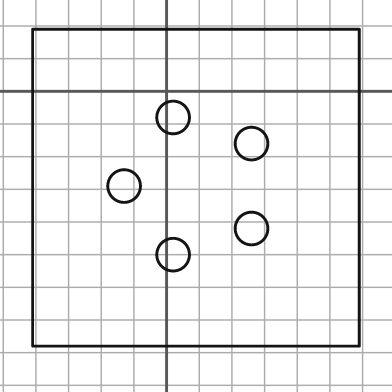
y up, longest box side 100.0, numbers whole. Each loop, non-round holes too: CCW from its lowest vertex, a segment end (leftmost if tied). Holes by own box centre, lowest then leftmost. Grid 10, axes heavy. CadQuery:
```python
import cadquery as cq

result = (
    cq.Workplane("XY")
    .moveTo(-41.0, -78.0)
    .lineTo(59.0, -78.0)
    .lineTo(59.0, 19.0)
    .lineTo(-41.0, 19.0)
    .close()
    .moveTo(2.0, -50.0)
    .circle(5.0)
    .moveTo(26.0, -42.0)
    .circle(5.0)
    .moveTo(-13.0, -29.0)
    .circle(5.0)
    .moveTo(26.0, -16.0)
    .circle(5.0)
    .moveTo(2.0, -8.0)
    .circle(5.0)
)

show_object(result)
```